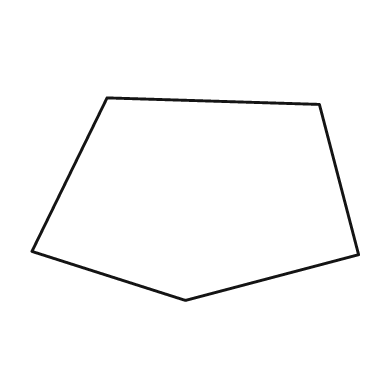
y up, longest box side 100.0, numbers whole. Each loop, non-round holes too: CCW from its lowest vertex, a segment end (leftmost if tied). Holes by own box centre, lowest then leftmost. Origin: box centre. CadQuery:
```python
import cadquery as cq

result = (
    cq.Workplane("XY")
    .moveTo(-3.0, -31.0)
    .lineTo(50.0, -17.0)
    .lineTo(38.0, 29.0)
    .lineTo(-27.0, 31.0)
    .lineTo(-50.0, -16.0)
    .close()
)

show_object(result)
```